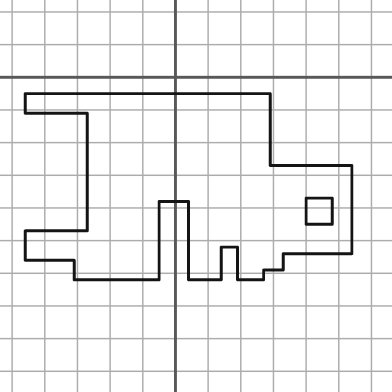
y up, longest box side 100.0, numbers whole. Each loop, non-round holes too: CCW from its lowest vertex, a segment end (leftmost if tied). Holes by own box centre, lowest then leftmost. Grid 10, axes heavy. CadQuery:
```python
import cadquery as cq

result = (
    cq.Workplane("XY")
    .moveTo(-31.0, -62.0)
    .lineTo(-5.0, -62.0)
    .lineTo(-5.0, -38.0)
    .lineTo(4.0, -38.0)
    .lineTo(4.0, -62.0)
    .lineTo(14.0, -62.0)
    .lineTo(14.0, -52.0)
    .lineTo(19.0, -52.0)
    .lineTo(19.0, -62.0)
    .lineTo(27.0, -62.0)
    .lineTo(27.0, -59.0)
    .lineTo(33.0, -59.0)
    .lineTo(33.0, -54.0)
    .lineTo(54.0, -54.0)
    .lineTo(54.0, -27.0)
    .lineTo(29.0, -27.0)
    .lineTo(29.0, -5.0)
    .lineTo(-46.0, -5.0)
    .lineTo(-46.0, -11.0)
    .lineTo(-27.0, -11.0)
    .lineTo(-27.0, -47.0)
    .lineTo(-46.0, -47.0)
    .lineTo(-46.0, -56.0)
    .lineTo(-31.0, -56.0)
    .close()
    .moveTo(40.0, -45.0)
    .lineTo(48.0, -45.0)
    .lineTo(48.0, -37.0)
    .lineTo(40.0, -37.0)
    .close()
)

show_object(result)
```